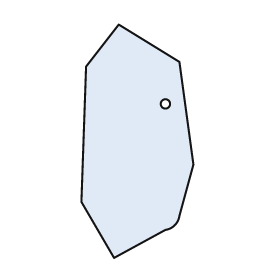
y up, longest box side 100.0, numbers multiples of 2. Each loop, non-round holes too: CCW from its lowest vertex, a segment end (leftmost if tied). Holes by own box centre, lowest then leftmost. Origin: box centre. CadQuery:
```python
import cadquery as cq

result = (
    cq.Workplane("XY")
    .moveTo(-10.0, -50.0)
    .lineTo(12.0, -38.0)
    .threePointArc((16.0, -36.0), (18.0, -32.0))
    .lineTo(24.0, -10.0)
    .lineTo(18.0, 34.0)
    .lineTo(-8.0, 50.0)
    .lineTo(-22.0, 32.0)
    .lineTo(-24.0, -26.0)
    .close()
    .moveTo(12.0, 16.0)
    .circle(2.0)
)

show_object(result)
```